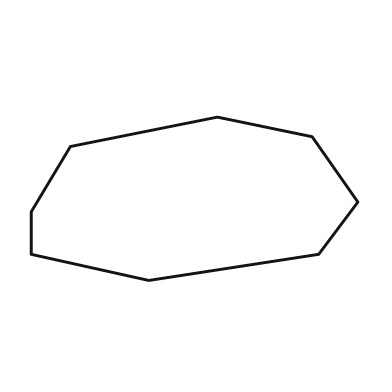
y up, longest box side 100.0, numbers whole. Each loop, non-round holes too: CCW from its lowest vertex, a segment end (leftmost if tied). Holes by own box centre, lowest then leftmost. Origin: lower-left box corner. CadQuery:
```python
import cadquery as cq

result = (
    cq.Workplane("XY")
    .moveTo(36.0, 0.0)
    .lineTo(88.0, 8.0)
    .lineTo(100.0, 24.0)
    .lineTo(86.0, 44.0)
    .lineTo(57.0, 50.0)
    .lineTo(12.0, 41.0)
    .lineTo(0.0, 21.0)
    .lineTo(0.0, 8.0)
    .close()
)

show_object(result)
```